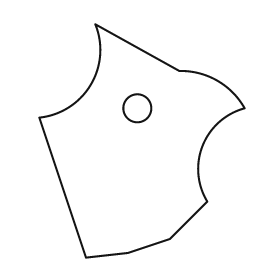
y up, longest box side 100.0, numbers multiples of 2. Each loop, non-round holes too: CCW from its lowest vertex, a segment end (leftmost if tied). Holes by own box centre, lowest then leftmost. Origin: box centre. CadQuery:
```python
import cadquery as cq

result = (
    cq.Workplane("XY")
    .moveTo(-24.0, -50.0)
    .lineTo(-6.0, -48.0)
    .lineTo(12.0, -42.0)
    .lineTo(28.0, -26.0)
    .threePointArc((26.0, -2.0), (44.0, 14.0))
    .threePointArc((32.0, 26.0), (16.0, 30.0))
    .lineTo(-20.0, 50.0)
    .threePointArc((-22.0, 24.0), (-44.0, 10.0))
    .close()
    .moveTo(-2.0, 14.0)
    .circle(6.0)
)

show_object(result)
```